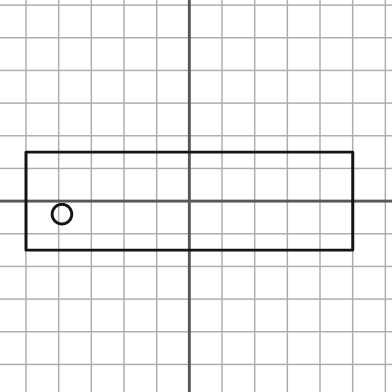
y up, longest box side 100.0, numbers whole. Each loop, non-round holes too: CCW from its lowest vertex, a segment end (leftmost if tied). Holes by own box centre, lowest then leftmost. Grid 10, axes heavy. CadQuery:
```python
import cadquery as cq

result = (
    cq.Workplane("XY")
    .moveTo(-50.0, -15.0)
    .lineTo(50.0, -15.0)
    .lineTo(50.0, 15.0)
    .lineTo(-50.0, 15.0)
    .close()
    .moveTo(-39.0, -4.0)
    .circle(3.0)
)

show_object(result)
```